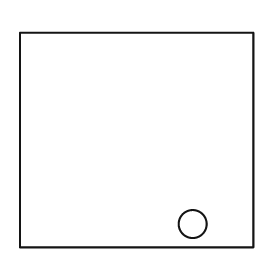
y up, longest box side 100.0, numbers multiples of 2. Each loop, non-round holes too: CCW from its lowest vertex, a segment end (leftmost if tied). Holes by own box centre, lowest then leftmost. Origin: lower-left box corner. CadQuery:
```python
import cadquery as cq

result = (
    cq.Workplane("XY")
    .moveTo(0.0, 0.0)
    .lineTo(100.0, 0.0)
    .lineTo(100.0, 92.0)
    .lineTo(0.0, 92.0)
    .close()
    .moveTo(74.0, 10.0)
    .circle(6.0)
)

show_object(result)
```